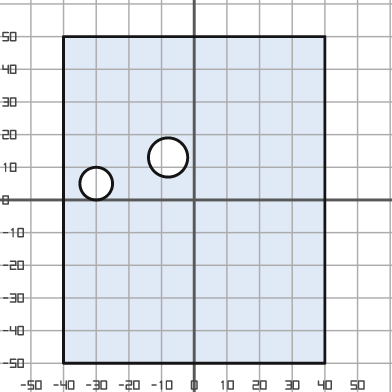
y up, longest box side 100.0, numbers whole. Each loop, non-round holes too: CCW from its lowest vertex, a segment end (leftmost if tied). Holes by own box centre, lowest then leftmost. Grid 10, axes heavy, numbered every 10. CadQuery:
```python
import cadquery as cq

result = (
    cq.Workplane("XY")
    .moveTo(-40.0, -50.0)
    .lineTo(40.0, -50.0)
    .lineTo(40.0, 50.0)
    .lineTo(-40.0, 50.0)
    .close()
    .moveTo(-30.0, 5.0)
    .circle(5.0)
    .moveTo(-8.0, 13.0)
    .circle(6.0)
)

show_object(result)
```